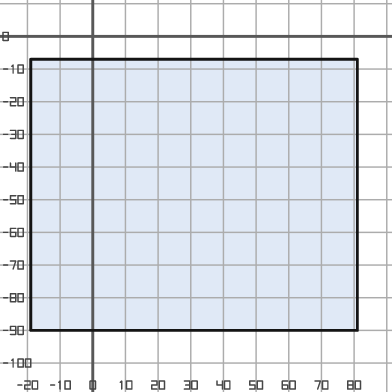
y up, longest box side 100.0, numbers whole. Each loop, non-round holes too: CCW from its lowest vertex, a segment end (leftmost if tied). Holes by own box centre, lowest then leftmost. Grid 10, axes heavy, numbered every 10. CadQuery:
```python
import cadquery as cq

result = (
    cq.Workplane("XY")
    .moveTo(-19.0, -90.0)
    .lineTo(81.0, -90.0)
    .lineTo(81.0, -7.0)
    .lineTo(-19.0, -7.0)
    .close()
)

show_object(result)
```